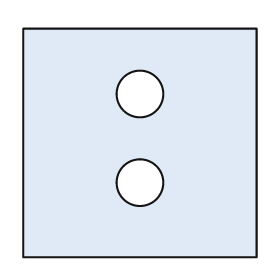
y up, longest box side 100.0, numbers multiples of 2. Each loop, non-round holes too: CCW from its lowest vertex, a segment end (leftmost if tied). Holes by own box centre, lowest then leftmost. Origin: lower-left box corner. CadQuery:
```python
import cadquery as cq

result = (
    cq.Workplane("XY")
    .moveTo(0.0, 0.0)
    .lineTo(100.0, 0.0)
    .lineTo(100.0, 98.0)
    .lineTo(0.0, 98.0)
    .close()
    .moveTo(50.0, 32.0)
    .circle(10.0)
    .moveTo(50.0, 70.0)
    .circle(10.0)
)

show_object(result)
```